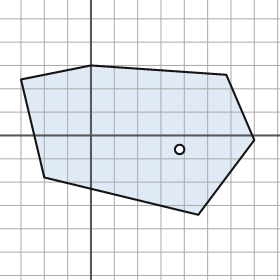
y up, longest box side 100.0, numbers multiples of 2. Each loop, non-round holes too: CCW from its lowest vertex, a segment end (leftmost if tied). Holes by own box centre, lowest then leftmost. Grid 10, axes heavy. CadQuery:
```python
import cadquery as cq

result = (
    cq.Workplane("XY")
    .moveTo(46.0, -34.0)
    .lineTo(70.0, -2.0)
    .lineTo(58.0, 26.0)
    .lineTo(0.0, 30.0)
    .lineTo(-30.0, 24.0)
    .lineTo(-20.0, -18.0)
    .close()
    .moveTo(38.0, -6.0)
    .circle(2.0)
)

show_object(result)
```